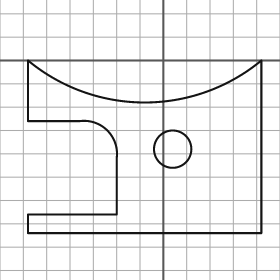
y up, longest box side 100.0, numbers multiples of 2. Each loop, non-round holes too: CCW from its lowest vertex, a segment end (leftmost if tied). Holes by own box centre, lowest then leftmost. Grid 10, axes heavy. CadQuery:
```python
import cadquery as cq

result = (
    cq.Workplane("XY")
    .moveTo(-58.0, -74.0)
    .lineTo(42.0, -74.0)
    .lineTo(42.0, 0.0)
    .threePointArc((-8.0, -18.0), (-58.0, 0.0))
    .lineTo(-58.0, -26.0)
    .lineTo(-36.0, -26.0)
    .threePointArc((-24.0, -30.0), (-20.0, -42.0))
    .lineTo(-20.0, -66.0)
    .lineTo(-58.0, -66.0)
    .close()
    .moveTo(4.0, -38.0)
    .circle(8.0)
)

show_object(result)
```